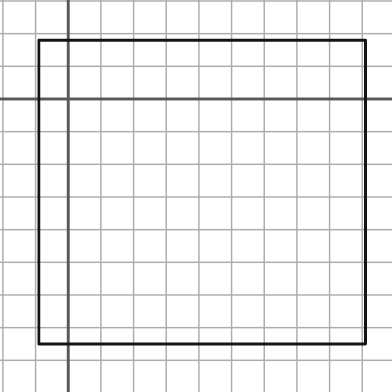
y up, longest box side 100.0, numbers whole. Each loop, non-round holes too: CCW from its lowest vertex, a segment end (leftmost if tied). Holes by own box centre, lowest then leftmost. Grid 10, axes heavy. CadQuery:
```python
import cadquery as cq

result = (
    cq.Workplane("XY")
    .moveTo(-9.0, -75.0)
    .lineTo(91.0, -75.0)
    .lineTo(91.0, 18.0)
    .lineTo(-9.0, 18.0)
    .close()
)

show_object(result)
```